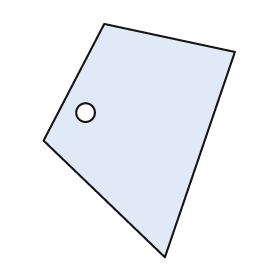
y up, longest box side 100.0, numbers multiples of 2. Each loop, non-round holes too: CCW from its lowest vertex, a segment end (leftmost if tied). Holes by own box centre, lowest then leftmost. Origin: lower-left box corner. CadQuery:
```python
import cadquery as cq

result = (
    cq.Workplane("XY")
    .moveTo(52.0, 0.0)
    .lineTo(82.0, 88.0)
    .lineTo(26.0, 100.0)
    .lineTo(0.0, 50.0)
    .close()
    .moveTo(18.0, 62.0)
    .circle(4.0)
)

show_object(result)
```